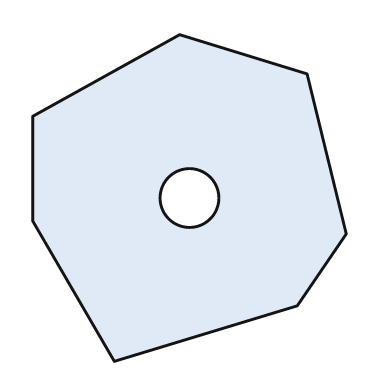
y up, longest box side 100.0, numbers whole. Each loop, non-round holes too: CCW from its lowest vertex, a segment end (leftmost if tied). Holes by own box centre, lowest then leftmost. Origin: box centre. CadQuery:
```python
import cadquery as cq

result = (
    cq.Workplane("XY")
    .moveTo(-23.0, -50.0)
    .lineTo(33.0, -33.0)
    .lineTo(48.0, -11.0)
    .lineTo(36.0, 38.0)
    .lineTo(-3.0, 50.0)
    .lineTo(-48.0, 25.0)
    .lineTo(-48.0, -7.0)
    .close()
    .moveTo(0.0, 0.0)
    .circle(9.0)
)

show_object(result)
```